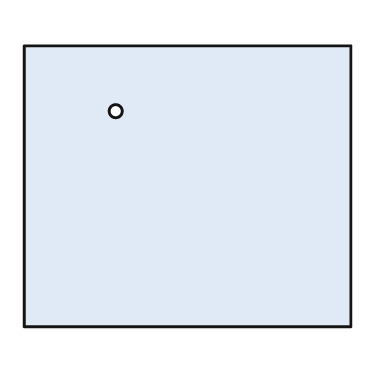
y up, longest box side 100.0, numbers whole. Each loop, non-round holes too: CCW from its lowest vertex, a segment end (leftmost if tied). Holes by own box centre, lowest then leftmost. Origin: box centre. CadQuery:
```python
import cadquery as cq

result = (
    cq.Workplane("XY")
    .moveTo(-50.0, -43.0)
    .lineTo(50.0, -43.0)
    .lineTo(50.0, 43.0)
    .lineTo(-50.0, 43.0)
    .close()
    .moveTo(-22.0, 23.0)
    .circle(2.0)
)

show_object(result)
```